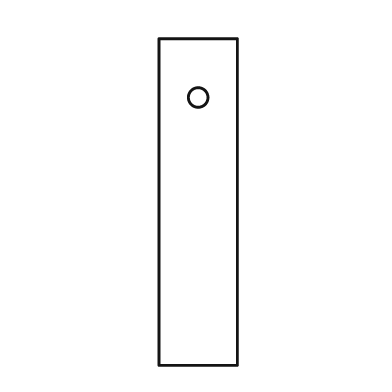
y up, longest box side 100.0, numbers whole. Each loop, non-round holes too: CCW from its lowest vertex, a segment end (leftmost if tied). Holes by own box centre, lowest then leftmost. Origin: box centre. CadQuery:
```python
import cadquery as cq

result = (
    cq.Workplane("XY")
    .moveTo(-12.0, -50.0)
    .lineTo(12.0, -50.0)
    .lineTo(12.0, 50.0)
    .lineTo(-12.0, 50.0)
    .close()
    .moveTo(0.0, 32.0)
    .circle(3.0)
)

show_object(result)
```